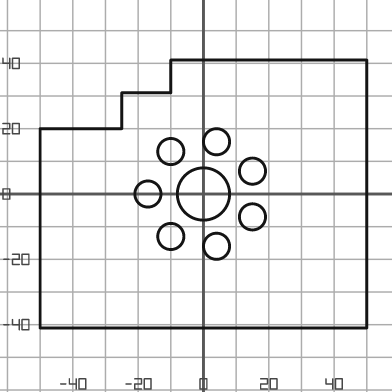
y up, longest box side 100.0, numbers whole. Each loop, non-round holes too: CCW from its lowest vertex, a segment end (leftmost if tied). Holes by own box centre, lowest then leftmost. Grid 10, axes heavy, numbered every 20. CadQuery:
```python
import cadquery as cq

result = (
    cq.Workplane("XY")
    .moveTo(-50.0, -41.0)
    .lineTo(50.0, -41.0)
    .lineTo(50.0, 41.0)
    .lineTo(-10.0, 41.0)
    .lineTo(-10.0, 31.0)
    .lineTo(-25.0, 31.0)
    .lineTo(-25.0, 20.0)
    .lineTo(-50.0, 20.0)
    .close()
    .moveTo(4.0, -16.0)
    .circle(4.0)
    .moveTo(-10.0, -13.0)
    .circle(4.0)
    .moveTo(15.0, -7.0)
    .circle(4.0)
    .moveTo(-17.0, 0.0)
    .circle(4.0)
    .moveTo(0.0, 0.0)
    .circle(8.0)
    .moveTo(15.0, 7.0)
    .circle(4.0)
    .moveTo(-10.0, 13.0)
    .circle(4.0)
    .moveTo(4.0, 16.0)
    .circle(4.0)
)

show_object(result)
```